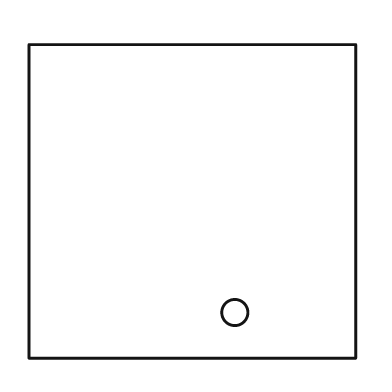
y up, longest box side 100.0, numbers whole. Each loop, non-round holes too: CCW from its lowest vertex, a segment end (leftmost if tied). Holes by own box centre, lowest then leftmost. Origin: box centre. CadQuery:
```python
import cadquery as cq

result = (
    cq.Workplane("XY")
    .moveTo(-50.0, -48.0)
    .lineTo(50.0, -48.0)
    .lineTo(50.0, 48.0)
    .lineTo(-50.0, 48.0)
    .close()
    .moveTo(13.0, -34.0)
    .circle(4.0)
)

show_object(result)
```